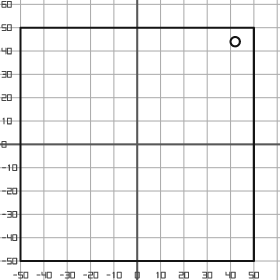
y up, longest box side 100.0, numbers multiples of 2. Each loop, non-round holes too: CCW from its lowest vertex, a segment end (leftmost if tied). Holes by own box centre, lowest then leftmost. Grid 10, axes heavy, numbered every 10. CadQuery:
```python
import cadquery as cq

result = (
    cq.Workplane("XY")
    .moveTo(-50.0, -50.0)
    .lineTo(50.0, -50.0)
    .lineTo(50.0, 50.0)
    .lineTo(-50.0, 50.0)
    .close()
    .moveTo(42.0, 44.0)
    .circle(2.0)
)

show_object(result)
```